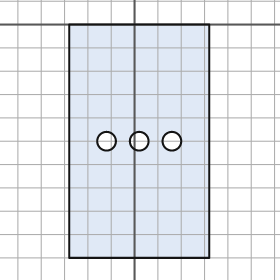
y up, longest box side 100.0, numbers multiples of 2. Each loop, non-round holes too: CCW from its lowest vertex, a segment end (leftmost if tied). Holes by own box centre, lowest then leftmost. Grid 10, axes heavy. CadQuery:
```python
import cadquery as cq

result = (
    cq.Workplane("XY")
    .moveTo(-28.0, -100.0)
    .lineTo(32.0, -100.0)
    .lineTo(32.0, 0.0)
    .lineTo(-28.0, 0.0)
    .close()
    .moveTo(-12.0, -50.0)
    .circle(4.0)
    .moveTo(2.0, -50.0)
    .circle(4.0)
    .moveTo(16.0, -50.0)
    .circle(4.0)
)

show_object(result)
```